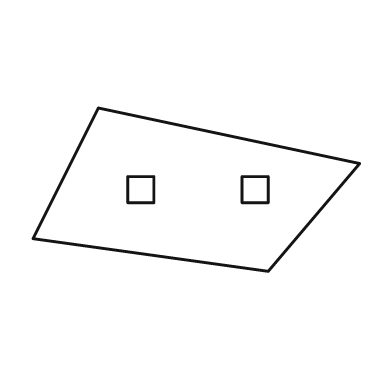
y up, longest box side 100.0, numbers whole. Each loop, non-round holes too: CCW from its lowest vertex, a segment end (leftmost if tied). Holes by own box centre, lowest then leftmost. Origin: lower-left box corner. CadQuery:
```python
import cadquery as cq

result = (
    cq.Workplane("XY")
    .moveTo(72.0, 0.0)
    .lineTo(100.0, 33.0)
    .lineTo(20.0, 50.0)
    .lineTo(0.0, 10.0)
    .close()
    .moveTo(29.0, 21.0)
    .lineTo(37.0, 21.0)
    .lineTo(37.0, 29.0)
    .lineTo(29.0, 29.0)
    .close()
    .moveTo(64.0, 21.0)
    .lineTo(72.0, 21.0)
    .lineTo(72.0, 29.0)
    .lineTo(64.0, 29.0)
    .close()
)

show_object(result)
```